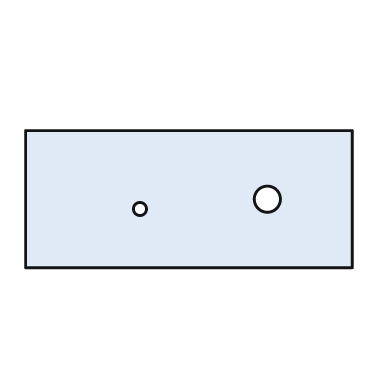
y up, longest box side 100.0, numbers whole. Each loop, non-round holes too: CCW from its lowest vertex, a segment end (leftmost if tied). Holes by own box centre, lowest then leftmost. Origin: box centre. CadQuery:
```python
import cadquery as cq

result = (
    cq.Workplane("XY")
    .moveTo(-50.0, -21.0)
    .lineTo(50.0, -21.0)
    .lineTo(50.0, 21.0)
    .lineTo(-50.0, 21.0)
    .close()
    .moveTo(-15.0, -3.0)
    .circle(2.0)
    .moveTo(24.0, 0.0)
    .circle(4.0)
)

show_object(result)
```